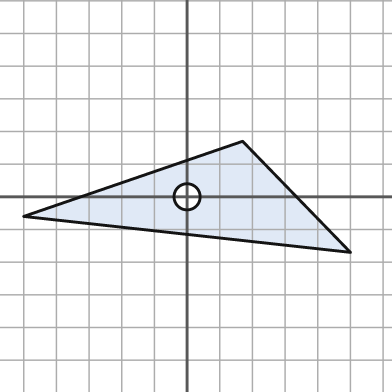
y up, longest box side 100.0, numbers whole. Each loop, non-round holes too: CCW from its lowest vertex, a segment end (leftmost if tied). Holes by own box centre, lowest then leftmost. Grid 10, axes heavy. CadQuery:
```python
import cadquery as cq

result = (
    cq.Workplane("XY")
    .moveTo(50.0, -17.0)
    .lineTo(17.0, 17.0)
    .lineTo(-50.0, -6.0)
    .close()
    .moveTo(0.0, 0.0)
    .circle(4.0)
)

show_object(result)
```